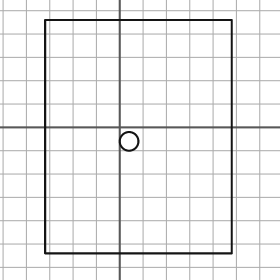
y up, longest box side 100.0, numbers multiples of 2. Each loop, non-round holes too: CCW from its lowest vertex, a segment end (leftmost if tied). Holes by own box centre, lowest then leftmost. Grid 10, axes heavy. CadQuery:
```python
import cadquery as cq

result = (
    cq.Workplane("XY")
    .moveTo(-32.0, -54.0)
    .lineTo(48.0, -54.0)
    .lineTo(48.0, 46.0)
    .lineTo(-32.0, 46.0)
    .close()
    .moveTo(4.0, -6.0)
    .circle(4.0)
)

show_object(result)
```